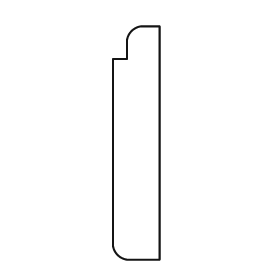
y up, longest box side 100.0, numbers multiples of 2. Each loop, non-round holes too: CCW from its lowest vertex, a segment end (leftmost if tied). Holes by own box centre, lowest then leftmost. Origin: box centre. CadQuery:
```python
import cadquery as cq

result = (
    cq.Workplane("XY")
    .moveTo(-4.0, -50.0)
    .lineTo(10.0, -50.0)
    .lineTo(10.0, 50.0)
    .lineTo(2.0, 50.0)
    .threePointArc((-2.0, 48.0), (-4.0, 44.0))
    .lineTo(-4.0, 36.0)
    .lineTo(-10.0, 36.0)
    .lineTo(-10.0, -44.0)
    .threePointArc((-8.0, -48.0), (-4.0, -50.0))
    .close()
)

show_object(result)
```